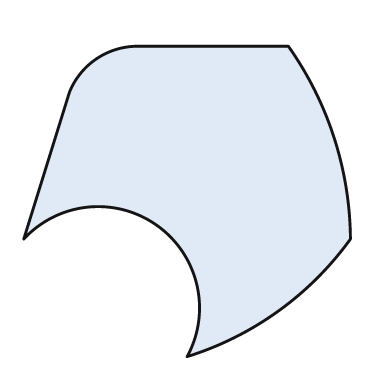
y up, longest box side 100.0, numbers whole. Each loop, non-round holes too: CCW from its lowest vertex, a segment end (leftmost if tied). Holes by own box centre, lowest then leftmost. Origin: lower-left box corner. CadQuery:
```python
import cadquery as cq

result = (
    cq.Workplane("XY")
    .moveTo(50.0, 0.0)
    .threePointArc((78.0, 14.0), (100.0, 36.0))
    .threePointArc((95.0, 67.0), (81.0, 95.0))
    .lineTo(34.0, 95.0)
    .threePointArc((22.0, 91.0), (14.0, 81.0))
    .lineTo(0.0, 36.0)
    .threePointArc((41.0, 40.0), (50.0, 0.0))
    .close()
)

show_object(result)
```